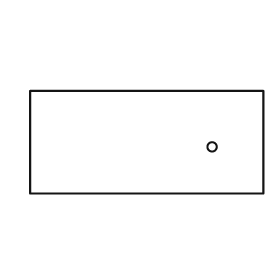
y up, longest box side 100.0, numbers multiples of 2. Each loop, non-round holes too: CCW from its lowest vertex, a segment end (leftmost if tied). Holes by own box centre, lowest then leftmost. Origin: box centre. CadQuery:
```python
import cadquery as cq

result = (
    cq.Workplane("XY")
    .moveTo(-50.0, -22.0)
    .lineTo(50.0, -22.0)
    .lineTo(50.0, 22.0)
    .lineTo(-50.0, 22.0)
    .close()
    .moveTo(28.0, -2.0)
    .circle(2.0)
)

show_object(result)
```